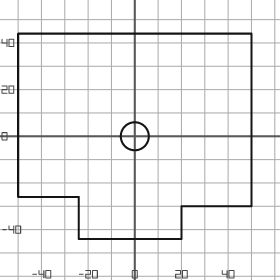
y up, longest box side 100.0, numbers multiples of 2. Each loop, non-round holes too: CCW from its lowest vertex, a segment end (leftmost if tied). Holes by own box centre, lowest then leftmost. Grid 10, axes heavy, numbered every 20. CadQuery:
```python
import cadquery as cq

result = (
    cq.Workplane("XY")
    .moveTo(-24.0, -44.0)
    .lineTo(20.0, -44.0)
    .lineTo(20.0, -30.0)
    .lineTo(50.0, -30.0)
    .lineTo(50.0, 44.0)
    .lineTo(-50.0, 44.0)
    .lineTo(-50.0, -26.0)
    .lineTo(-24.0, -26.0)
    .close()
    .moveTo(0.0, 0.0)
    .circle(6.0)
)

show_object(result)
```